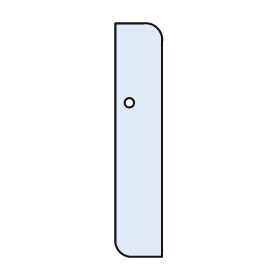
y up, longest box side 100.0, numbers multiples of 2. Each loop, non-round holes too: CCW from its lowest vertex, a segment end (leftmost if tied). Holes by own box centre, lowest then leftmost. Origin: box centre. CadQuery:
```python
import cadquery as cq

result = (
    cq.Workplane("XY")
    .moveTo(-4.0, -50.0)
    .lineTo(10.0, -50.0)
    .lineTo(10.0, 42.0)
    .threePointArc((8.0, 48.0), (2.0, 50.0))
    .lineTo(-10.0, 50.0)
    .lineTo(-10.0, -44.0)
    .threePointArc((-8.0, -48.0), (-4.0, -50.0))
    .close()
    .moveTo(-4.0, 16.0)
    .circle(2.0)
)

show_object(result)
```